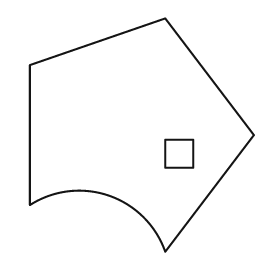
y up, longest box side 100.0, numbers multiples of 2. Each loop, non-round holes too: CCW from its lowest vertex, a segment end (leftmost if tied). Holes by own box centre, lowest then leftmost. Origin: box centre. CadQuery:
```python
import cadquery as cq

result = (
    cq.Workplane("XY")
    .moveTo(10.0, -50.0)
    .lineTo(48.0, 0.0)
    .lineTo(10.0, 50.0)
    .lineTo(-48.0, 30.0)
    .lineTo(-48.0, -30.0)
    .threePointArc((-14.0, -26.0), (10.0, -50.0))
    .close()
    .moveTo(10.0, -14.0)
    .lineTo(22.0, -14.0)
    .lineTo(22.0, -2.0)
    .lineTo(10.0, -2.0)
    .close()
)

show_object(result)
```